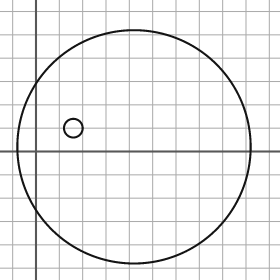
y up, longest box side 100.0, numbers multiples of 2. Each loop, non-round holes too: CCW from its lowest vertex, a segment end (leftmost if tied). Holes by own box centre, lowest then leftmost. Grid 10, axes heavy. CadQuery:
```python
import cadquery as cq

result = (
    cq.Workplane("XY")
    .moveTo(42.0, 2.0)
    .circle(50.0)
    .moveTo(16.0, 10.0)
    .circle(4.0)
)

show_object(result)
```